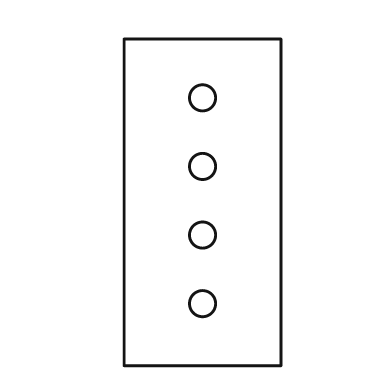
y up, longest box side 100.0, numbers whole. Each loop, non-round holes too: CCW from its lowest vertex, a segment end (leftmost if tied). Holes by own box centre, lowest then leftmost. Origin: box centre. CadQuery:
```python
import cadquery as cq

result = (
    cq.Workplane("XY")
    .moveTo(-24.0, -50.0)
    .lineTo(24.0, -50.0)
    .lineTo(24.0, 50.0)
    .lineTo(-24.0, 50.0)
    .close()
    .moveTo(0.0, -31.0)
    .circle(4.0)
    .moveTo(0.0, -10.0)
    .circle(4.0)
    .moveTo(0.0, 11.0)
    .circle(4.0)
    .moveTo(0.0, 32.0)
    .circle(4.0)
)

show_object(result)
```